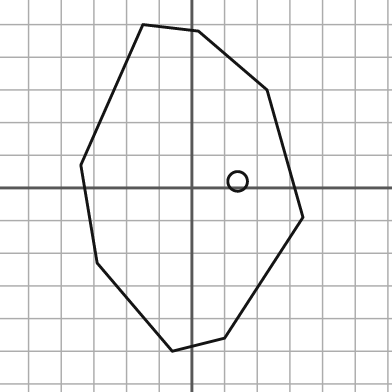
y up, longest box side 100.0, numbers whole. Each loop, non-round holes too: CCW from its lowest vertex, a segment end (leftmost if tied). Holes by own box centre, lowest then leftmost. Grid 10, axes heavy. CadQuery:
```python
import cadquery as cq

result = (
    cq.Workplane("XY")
    .moveTo(-6.0, -50.0)
    .lineTo(10.0, -46.0)
    .lineTo(34.0, -9.0)
    .lineTo(23.0, 30.0)
    .lineTo(2.0, 48.0)
    .lineTo(-15.0, 50.0)
    .lineTo(-34.0, 7.0)
    .lineTo(-29.0, -23.0)
    .close()
    .moveTo(14.0, 2.0)
    .circle(3.0)
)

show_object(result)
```